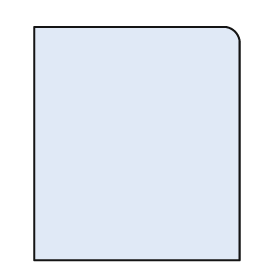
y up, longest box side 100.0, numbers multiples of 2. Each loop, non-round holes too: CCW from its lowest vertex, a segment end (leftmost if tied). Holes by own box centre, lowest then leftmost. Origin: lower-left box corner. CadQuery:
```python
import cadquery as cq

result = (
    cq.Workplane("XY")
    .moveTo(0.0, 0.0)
    .lineTo(88.0, 0.0)
    .lineTo(88.0, 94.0)
    .threePointArc((86.0, 98.0), (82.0, 100.0))
    .lineTo(0.0, 100.0)
    .close()
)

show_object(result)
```